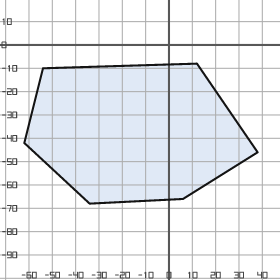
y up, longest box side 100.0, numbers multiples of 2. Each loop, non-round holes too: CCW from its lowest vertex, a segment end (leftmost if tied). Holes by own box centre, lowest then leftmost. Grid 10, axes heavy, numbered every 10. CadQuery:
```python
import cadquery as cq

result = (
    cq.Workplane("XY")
    .moveTo(-34.0, -68.0)
    .lineTo(6.0, -66.0)
    .lineTo(38.0, -46.0)
    .lineTo(12.0, -8.0)
    .lineTo(-54.0, -10.0)
    .lineTo(-62.0, -42.0)
    .close()
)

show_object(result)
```